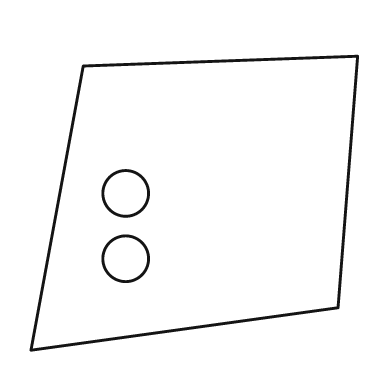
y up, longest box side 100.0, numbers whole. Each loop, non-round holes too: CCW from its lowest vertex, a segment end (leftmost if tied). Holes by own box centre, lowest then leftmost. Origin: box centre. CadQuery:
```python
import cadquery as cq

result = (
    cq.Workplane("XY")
    .moveTo(-50.0, -45.0)
    .lineTo(44.0, -32.0)
    .lineTo(50.0, 45.0)
    .lineTo(-34.0, 42.0)
    .close()
    .moveTo(-21.0, -17.0)
    .circle(7.0)
    .moveTo(-21.0, 3.0)
    .circle(7.0)
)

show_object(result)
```